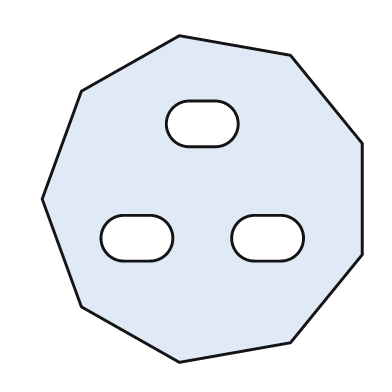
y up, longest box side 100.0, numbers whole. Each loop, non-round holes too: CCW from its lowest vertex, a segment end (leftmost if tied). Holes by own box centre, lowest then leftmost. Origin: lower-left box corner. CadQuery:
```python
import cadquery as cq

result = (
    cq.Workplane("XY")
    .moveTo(42.0, 0.0)
    .lineTo(76.0, 6.0)
    .lineTo(98.0, 33.0)
    .lineTo(98.0, 67.0)
    .lineTo(76.0, 94.0)
    .lineTo(42.0, 100.0)
    .lineTo(12.0, 83.0)
    .lineTo(0.0, 50.0)
    .lineTo(12.0, 17.0)
    .close()
    .moveTo(25.0, 31.0)
    .lineTo(33.0, 31.0)
    .threePointArc((40.0, 38.0), (33.0, 45.0))
    .lineTo(25.0, 45.0)
    .threePointArc((18.0, 38.0), (25.0, 31.0))
    .close()
    .moveTo(65.0, 31.0)
    .lineTo(73.0, 31.0)
    .threePointArc((80.0, 38.0), (73.0, 45.0))
    .lineTo(65.0, 45.0)
    .threePointArc((58.0, 38.0), (65.0, 31.0))
    .close()
    .moveTo(45.0, 66.0)
    .lineTo(53.0, 66.0)
    .threePointArc((60.0, 73.0), (53.0, 80.0))
    .lineTo(45.0, 80.0)
    .threePointArc((38.0, 73.0), (45.0, 66.0))
    .close()
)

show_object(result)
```